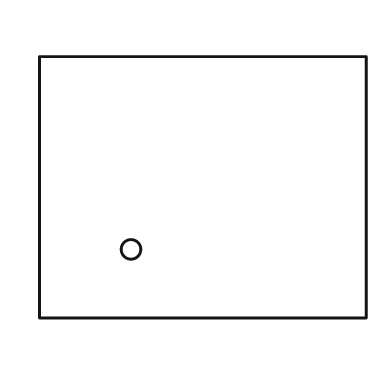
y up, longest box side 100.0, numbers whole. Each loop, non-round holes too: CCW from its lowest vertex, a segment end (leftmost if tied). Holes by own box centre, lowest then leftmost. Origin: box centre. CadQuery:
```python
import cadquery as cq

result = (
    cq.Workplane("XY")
    .moveTo(-50.0, -40.0)
    .lineTo(50.0, -40.0)
    .lineTo(50.0, 40.0)
    .lineTo(-50.0, 40.0)
    .close()
    .moveTo(-22.0, -19.0)
    .circle(3.0)
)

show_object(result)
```